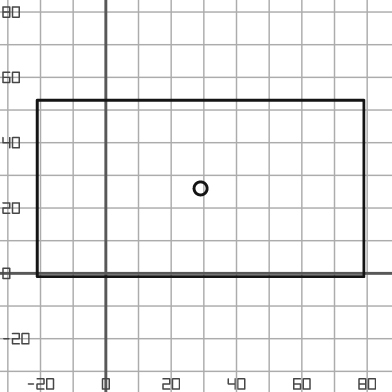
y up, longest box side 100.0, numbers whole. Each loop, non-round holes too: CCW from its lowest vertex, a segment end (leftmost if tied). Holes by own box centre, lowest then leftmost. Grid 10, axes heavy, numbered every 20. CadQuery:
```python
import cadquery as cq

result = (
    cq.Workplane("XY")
    .moveTo(-21.0, -1.0)
    .lineTo(79.0, -1.0)
    .lineTo(79.0, 53.0)
    .lineTo(-21.0, 53.0)
    .close()
    .moveTo(29.0, 26.0)
    .circle(2.0)
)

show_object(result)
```